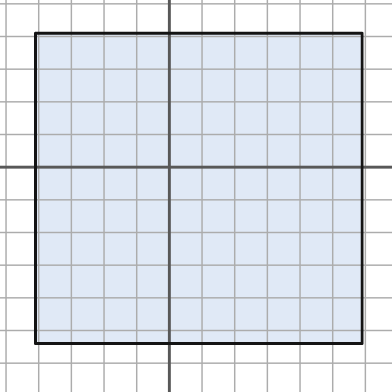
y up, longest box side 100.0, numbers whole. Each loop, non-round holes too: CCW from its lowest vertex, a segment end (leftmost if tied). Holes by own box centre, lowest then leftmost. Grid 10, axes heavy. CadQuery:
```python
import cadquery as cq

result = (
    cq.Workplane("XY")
    .moveTo(-41.0, -54.0)
    .lineTo(59.0, -54.0)
    .lineTo(59.0, 41.0)
    .lineTo(-41.0, 41.0)
    .close()
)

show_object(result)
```